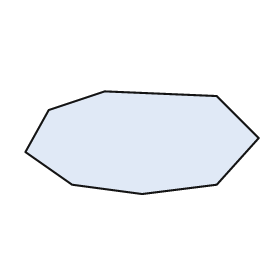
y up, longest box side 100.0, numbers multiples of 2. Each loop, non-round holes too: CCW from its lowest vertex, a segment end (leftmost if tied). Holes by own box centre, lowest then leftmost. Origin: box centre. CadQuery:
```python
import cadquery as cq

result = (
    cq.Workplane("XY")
    .moveTo(0.0, -22.0)
    .lineTo(32.0, -18.0)
    .lineTo(50.0, 2.0)
    .lineTo(32.0, 20.0)
    .lineTo(-16.0, 22.0)
    .lineTo(-40.0, 14.0)
    .lineTo(-50.0, -4.0)
    .lineTo(-30.0, -18.0)
    .close()
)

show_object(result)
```